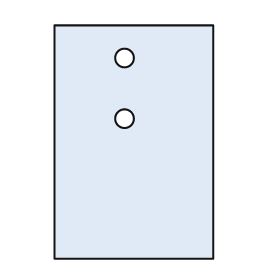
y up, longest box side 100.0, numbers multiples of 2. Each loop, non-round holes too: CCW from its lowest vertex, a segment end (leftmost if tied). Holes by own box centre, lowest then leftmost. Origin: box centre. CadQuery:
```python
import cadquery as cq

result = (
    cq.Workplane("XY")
    .moveTo(-34.0, -50.0)
    .lineTo(34.0, -50.0)
    .lineTo(34.0, 50.0)
    .lineTo(-34.0, 50.0)
    .close()
    .moveTo(-4.0, 10.0)
    .circle(4.0)
    .moveTo(-4.0, 36.0)
    .circle(4.0)
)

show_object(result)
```